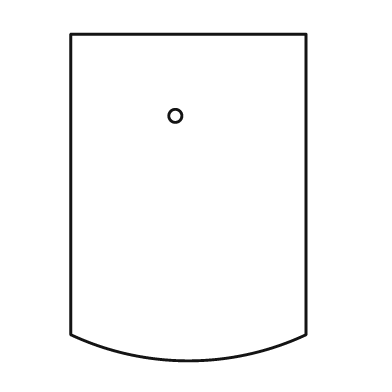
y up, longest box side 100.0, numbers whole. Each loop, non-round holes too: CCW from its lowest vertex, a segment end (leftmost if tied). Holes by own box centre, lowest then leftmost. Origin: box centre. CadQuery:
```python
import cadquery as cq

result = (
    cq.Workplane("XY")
    .moveTo(-36.0, -42.0)
    .threePointArc((0.0, -50.0), (36.0, -42.0))
    .lineTo(36.0, 50.0)
    .lineTo(-36.0, 50.0)
    .close()
    .moveTo(-4.0, 25.0)
    .circle(2.0)
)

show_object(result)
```